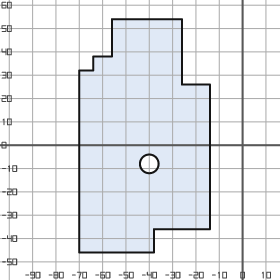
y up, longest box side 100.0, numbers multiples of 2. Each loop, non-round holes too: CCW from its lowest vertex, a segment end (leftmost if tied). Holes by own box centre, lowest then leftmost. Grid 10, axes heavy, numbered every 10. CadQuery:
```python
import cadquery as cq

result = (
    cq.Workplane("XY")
    .moveTo(-70.0, -46.0)
    .lineTo(-38.0, -46.0)
    .lineTo(-38.0, -36.0)
    .lineTo(-14.0, -36.0)
    .lineTo(-14.0, 26.0)
    .lineTo(-26.0, 26.0)
    .lineTo(-26.0, 54.0)
    .lineTo(-56.0, 54.0)
    .lineTo(-56.0, 38.0)
    .lineTo(-64.0, 38.0)
    .lineTo(-64.0, 32.0)
    .lineTo(-70.0, 32.0)
    .close()
    .moveTo(-40.0, -8.0)
    .circle(4.0)
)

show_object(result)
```